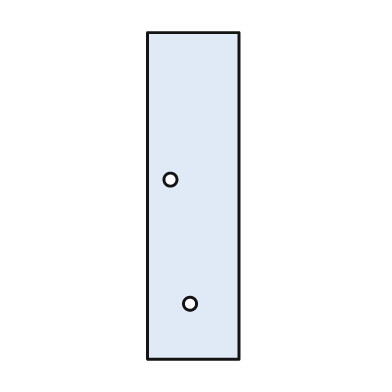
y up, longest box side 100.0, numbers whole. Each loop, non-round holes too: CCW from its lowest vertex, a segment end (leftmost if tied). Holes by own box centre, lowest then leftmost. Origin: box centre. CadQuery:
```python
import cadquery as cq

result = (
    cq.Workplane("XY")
    .moveTo(-14.0, -50.0)
    .lineTo(14.0, -50.0)
    .lineTo(14.0, 50.0)
    .lineTo(-14.0, 50.0)
    .close()
    .moveTo(-1.0, -33.0)
    .circle(2.0)
    .moveTo(-7.0, 5.0)
    .circle(2.0)
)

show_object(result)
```